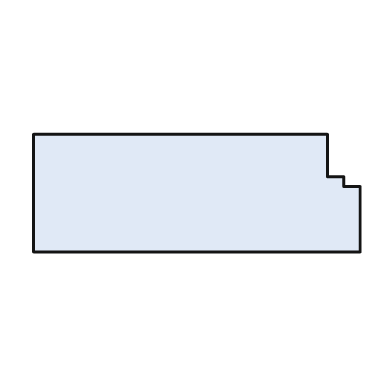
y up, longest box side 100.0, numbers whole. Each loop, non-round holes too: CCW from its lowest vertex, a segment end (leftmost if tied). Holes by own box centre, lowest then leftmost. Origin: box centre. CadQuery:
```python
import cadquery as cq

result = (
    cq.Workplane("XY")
    .moveTo(-50.0, -18.0)
    .lineTo(50.0, -18.0)
    .lineTo(50.0, 2.0)
    .lineTo(45.0, 2.0)
    .lineTo(45.0, 5.0)
    .lineTo(40.0, 5.0)
    .lineTo(40.0, 18.0)
    .lineTo(-50.0, 18.0)
    .close()
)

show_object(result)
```